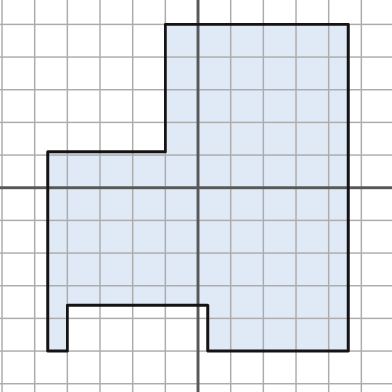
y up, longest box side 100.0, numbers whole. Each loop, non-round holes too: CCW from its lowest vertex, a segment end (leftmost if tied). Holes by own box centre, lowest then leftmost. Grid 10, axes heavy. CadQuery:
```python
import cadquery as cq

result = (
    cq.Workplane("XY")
    .moveTo(-46.0, -50.0)
    .lineTo(-40.0, -50.0)
    .lineTo(-40.0, -36.0)
    .lineTo(3.0, -36.0)
    .lineTo(3.0, -50.0)
    .lineTo(46.0, -50.0)
    .lineTo(46.0, 50.0)
    .lineTo(-10.0, 50.0)
    .lineTo(-10.0, 11.0)
    .lineTo(-46.0, 11.0)
    .close()
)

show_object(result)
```